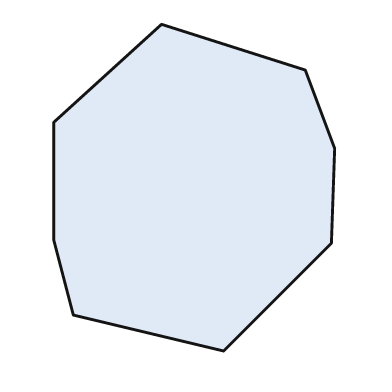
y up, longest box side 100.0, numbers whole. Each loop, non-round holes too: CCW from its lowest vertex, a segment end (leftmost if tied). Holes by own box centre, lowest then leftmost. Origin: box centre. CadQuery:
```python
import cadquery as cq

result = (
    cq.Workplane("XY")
    .moveTo(9.0, -50.0)
    .lineTo(42.0, -17.0)
    .lineTo(43.0, 12.0)
    .lineTo(34.0, 36.0)
    .lineTo(-10.0, 50.0)
    .lineTo(-43.0, 20.0)
    .lineTo(-43.0, -16.0)
    .lineTo(-37.0, -39.0)
    .close()
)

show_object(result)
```